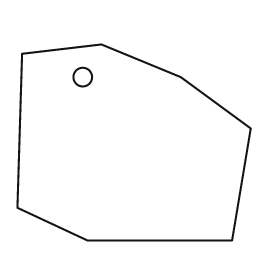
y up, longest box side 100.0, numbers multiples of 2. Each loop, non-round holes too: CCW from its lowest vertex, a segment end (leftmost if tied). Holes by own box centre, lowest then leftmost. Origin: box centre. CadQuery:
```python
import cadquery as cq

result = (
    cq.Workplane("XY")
    .moveTo(-20.0, -42.0)
    .lineTo(42.0, -42.0)
    .lineTo(50.0, 6.0)
    .lineTo(20.0, 28.0)
    .lineTo(-14.0, 42.0)
    .lineTo(-48.0, 38.0)
    .lineTo(-50.0, -28.0)
    .close()
    .moveTo(-22.0, 28.0)
    .circle(4.0)
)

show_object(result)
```